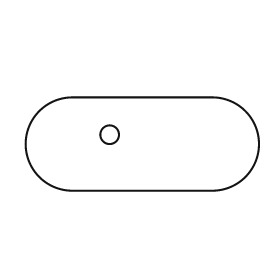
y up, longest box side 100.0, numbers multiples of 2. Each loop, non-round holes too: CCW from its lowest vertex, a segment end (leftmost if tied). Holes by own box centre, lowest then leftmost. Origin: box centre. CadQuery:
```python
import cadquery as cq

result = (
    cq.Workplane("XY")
    .moveTo(-30.0, -20.0)
    .lineTo(30.0, -20.0)
    .threePointArc((50.0, 0.0), (30.0, 20.0))
    .lineTo(-30.0, 20.0)
    .threePointArc((-50.0, 0.0), (-30.0, -20.0))
    .close()
    .moveTo(-14.0, 4.0)
    .circle(4.0)
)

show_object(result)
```